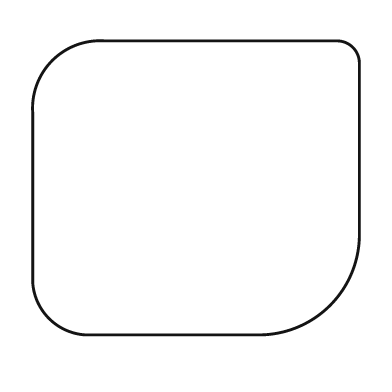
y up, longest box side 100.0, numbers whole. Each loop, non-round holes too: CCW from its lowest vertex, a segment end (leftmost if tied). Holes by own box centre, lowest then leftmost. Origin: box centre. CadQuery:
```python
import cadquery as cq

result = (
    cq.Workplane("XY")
    .moveTo(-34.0, -45.0)
    .lineTo(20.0, -45.0)
    .threePointArc((41.0, -36.0), (50.0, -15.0))
    .lineTo(50.0, 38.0)
    .threePointArc((48.0, 43.0), (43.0, 45.0))
    .lineTo(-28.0, 45.0)
    .threePointArc((-44.0, 39.0), (-50.0, 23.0))
    .lineTo(-50.0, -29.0)
    .threePointArc((-45.0, -40.0), (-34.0, -45.0))
    .close()
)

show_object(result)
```